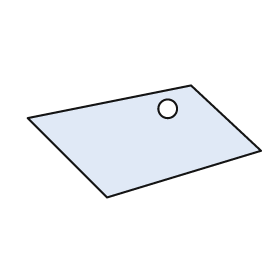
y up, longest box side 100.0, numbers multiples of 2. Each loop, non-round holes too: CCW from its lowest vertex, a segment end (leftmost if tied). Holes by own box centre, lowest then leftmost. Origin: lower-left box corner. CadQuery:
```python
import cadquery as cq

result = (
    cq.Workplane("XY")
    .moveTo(34.0, 0.0)
    .lineTo(100.0, 20.0)
    .lineTo(70.0, 48.0)
    .lineTo(0.0, 34.0)
    .close()
    .moveTo(60.0, 38.0)
    .circle(4.0)
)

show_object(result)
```